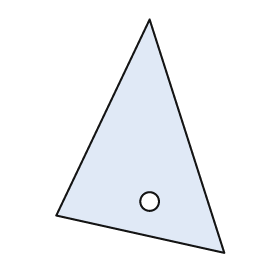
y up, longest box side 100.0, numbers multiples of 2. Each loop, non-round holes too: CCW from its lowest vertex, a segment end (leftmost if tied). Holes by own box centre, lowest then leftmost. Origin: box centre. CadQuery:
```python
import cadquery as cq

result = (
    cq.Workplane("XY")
    .moveTo(36.0, -50.0)
    .lineTo(4.0, 50.0)
    .lineTo(-36.0, -34.0)
    .close()
    .moveTo(4.0, -28.0)
    .circle(4.0)
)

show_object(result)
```